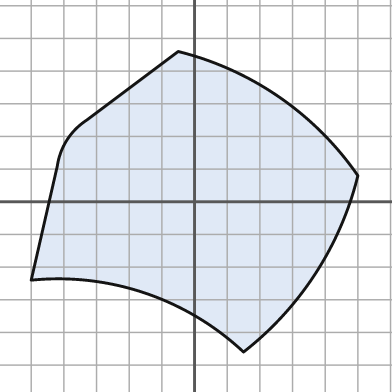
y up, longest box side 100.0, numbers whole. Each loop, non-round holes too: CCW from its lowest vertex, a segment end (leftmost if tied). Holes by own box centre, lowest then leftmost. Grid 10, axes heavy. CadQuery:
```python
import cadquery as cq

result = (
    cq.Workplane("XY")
    .moveTo(15.0, -46.0)
    .threePointArc((37.0, -22.0), (50.0, 8.0))
    .threePointArc((26.0, 32.0), (-5.0, 46.0))
    .lineTo(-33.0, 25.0)
    .threePointArc((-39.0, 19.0), (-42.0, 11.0))
    .lineTo(-50.0, -24.0)
    .threePointArc((-15.0, -28.0), (15.0, -46.0))
    .close()
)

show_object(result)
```